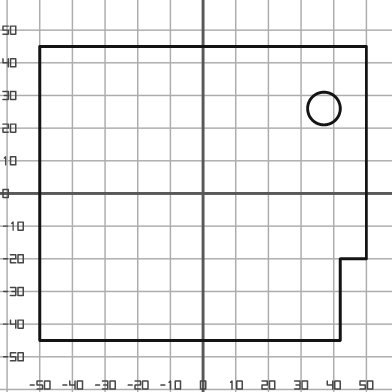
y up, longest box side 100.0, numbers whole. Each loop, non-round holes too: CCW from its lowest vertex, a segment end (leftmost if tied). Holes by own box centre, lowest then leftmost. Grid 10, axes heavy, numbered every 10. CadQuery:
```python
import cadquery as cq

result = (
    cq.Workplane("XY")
    .moveTo(-50.0, -45.0)
    .lineTo(42.0, -45.0)
    .lineTo(42.0, -20.0)
    .lineTo(50.0, -20.0)
    .lineTo(50.0, 45.0)
    .lineTo(-50.0, 45.0)
    .close()
    .moveTo(37.0, 26.0)
    .circle(5.0)
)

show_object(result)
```